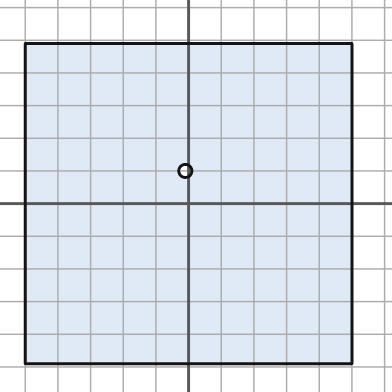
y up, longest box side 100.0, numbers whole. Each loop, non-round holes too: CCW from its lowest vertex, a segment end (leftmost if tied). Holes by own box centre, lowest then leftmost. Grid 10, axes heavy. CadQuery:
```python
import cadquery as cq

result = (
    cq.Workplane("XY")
    .moveTo(-50.0, -49.0)
    .lineTo(50.0, -49.0)
    .lineTo(50.0, 49.0)
    .lineTo(-50.0, 49.0)
    .close()
    .moveTo(-1.0, 10.0)
    .circle(2.0)
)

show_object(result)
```